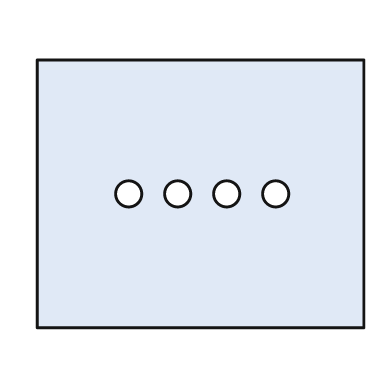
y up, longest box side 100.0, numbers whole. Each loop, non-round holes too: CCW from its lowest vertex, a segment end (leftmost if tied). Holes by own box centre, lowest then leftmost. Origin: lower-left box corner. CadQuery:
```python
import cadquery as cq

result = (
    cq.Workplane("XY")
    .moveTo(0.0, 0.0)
    .lineTo(100.0, 0.0)
    .lineTo(100.0, 82.0)
    .lineTo(0.0, 82.0)
    .close()
    .moveTo(28.0, 41.0)
    .circle(4.0)
    .moveTo(43.0, 41.0)
    .circle(4.0)
    .moveTo(58.0, 41.0)
    .circle(4.0)
    .moveTo(73.0, 41.0)
    .circle(4.0)
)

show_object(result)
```